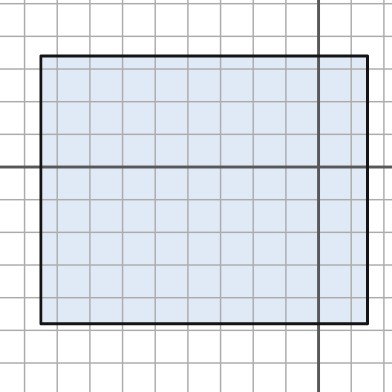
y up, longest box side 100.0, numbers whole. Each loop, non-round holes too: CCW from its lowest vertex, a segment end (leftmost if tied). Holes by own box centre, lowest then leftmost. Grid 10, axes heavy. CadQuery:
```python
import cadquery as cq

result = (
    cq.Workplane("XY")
    .moveTo(-85.0, -48.0)
    .lineTo(15.0, -48.0)
    .lineTo(15.0, 34.0)
    .lineTo(-85.0, 34.0)
    .close()
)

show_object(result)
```